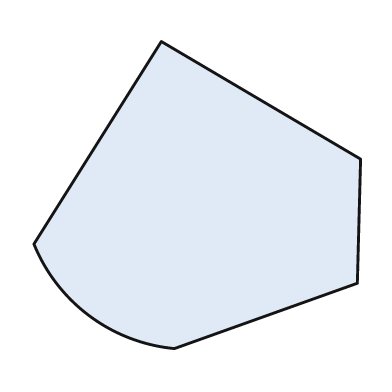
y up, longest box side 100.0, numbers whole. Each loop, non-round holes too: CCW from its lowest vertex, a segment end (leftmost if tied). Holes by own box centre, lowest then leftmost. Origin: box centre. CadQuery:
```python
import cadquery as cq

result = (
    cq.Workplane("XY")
    .moveTo(-7.0, -47.0)
    .lineTo(49.0, -27.0)
    .lineTo(50.0, 11.0)
    .lineTo(-11.0, 47.0)
    .lineTo(-50.0, -15.0)
    .threePointArc((-33.0, -37.0), (-7.0, -47.0))
    .close()
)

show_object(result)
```